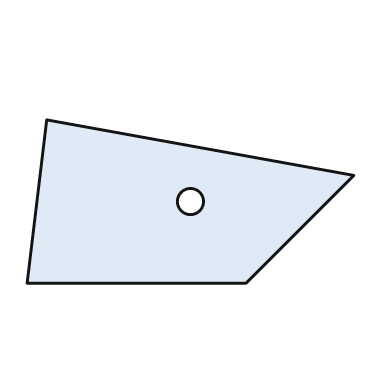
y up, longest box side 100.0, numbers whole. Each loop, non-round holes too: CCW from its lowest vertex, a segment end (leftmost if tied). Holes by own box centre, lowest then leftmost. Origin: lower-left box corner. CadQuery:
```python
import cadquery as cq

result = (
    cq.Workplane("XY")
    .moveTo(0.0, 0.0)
    .lineTo(67.0, 0.0)
    .lineTo(100.0, 33.0)
    .lineTo(6.0, 50.0)
    .close()
    .moveTo(50.0, 25.0)
    .circle(4.0)
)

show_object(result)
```